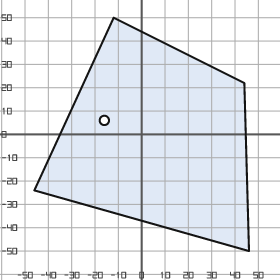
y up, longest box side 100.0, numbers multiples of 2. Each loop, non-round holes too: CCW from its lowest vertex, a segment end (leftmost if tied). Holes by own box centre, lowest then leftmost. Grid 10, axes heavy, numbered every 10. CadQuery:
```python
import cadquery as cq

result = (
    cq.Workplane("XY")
    .moveTo(46.0, -50.0)
    .lineTo(44.0, 22.0)
    .lineTo(-12.0, 50.0)
    .lineTo(-46.0, -24.0)
    .close()
    .moveTo(-16.0, 6.0)
    .circle(2.0)
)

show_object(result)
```